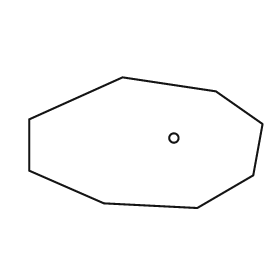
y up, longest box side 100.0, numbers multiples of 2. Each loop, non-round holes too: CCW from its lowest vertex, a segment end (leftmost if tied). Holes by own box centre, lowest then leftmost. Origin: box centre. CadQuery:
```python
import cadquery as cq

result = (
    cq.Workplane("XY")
    .moveTo(22.0, -28.0)
    .lineTo(46.0, -14.0)
    .lineTo(50.0, 8.0)
    .lineTo(30.0, 22.0)
    .lineTo(-10.0, 28.0)
    .lineTo(-50.0, 10.0)
    .lineTo(-50.0, -12.0)
    .lineTo(-18.0, -26.0)
    .close()
    .moveTo(12.0, 2.0)
    .circle(2.0)
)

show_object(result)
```